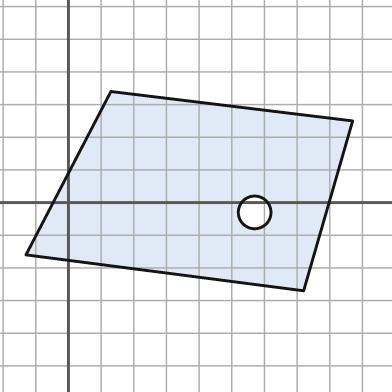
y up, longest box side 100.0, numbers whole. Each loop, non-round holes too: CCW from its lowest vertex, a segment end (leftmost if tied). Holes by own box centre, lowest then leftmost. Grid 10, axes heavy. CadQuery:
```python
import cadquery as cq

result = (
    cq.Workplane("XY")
    .moveTo(72.0, -27.0)
    .lineTo(87.0, 25.0)
    .lineTo(13.0, 34.0)
    .lineTo(-13.0, -16.0)
    .close()
    .moveTo(57.0, -3.0)
    .circle(5.0)
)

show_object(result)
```